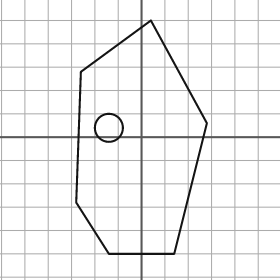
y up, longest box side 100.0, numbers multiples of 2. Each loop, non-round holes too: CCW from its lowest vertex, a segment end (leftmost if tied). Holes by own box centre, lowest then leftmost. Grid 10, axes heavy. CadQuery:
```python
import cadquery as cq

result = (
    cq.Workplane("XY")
    .moveTo(-14.0, -50.0)
    .lineTo(14.0, -50.0)
    .lineTo(28.0, 6.0)
    .lineTo(4.0, 50.0)
    .lineTo(-26.0, 28.0)
    .lineTo(-28.0, -28.0)
    .close()
    .moveTo(-14.0, 4.0)
    .circle(6.0)
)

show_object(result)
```